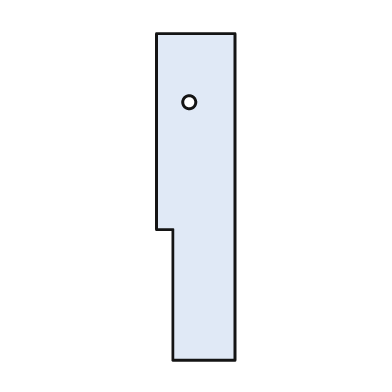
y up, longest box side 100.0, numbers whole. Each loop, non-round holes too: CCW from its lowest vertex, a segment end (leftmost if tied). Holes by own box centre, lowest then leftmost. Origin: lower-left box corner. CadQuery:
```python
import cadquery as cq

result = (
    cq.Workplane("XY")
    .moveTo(5.0, 0.0)
    .lineTo(24.0, 0.0)
    .lineTo(24.0, 100.0)
    .lineTo(0.0, 100.0)
    .lineTo(0.0, 40.0)
    .lineTo(5.0, 40.0)
    .close()
    .moveTo(10.0, 79.0)
    .circle(2.0)
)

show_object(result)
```